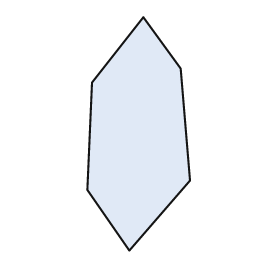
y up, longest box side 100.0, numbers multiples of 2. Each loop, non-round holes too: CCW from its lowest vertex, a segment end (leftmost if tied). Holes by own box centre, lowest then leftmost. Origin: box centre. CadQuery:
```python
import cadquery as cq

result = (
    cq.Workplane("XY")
    .moveTo(-4.0, -50.0)
    .lineTo(22.0, -20.0)
    .lineTo(18.0, 28.0)
    .lineTo(2.0, 50.0)
    .lineTo(-20.0, 22.0)
    .lineTo(-22.0, -24.0)
    .close()
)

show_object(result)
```